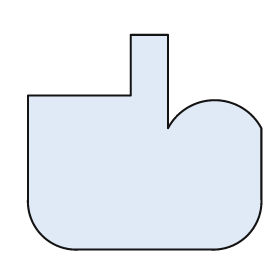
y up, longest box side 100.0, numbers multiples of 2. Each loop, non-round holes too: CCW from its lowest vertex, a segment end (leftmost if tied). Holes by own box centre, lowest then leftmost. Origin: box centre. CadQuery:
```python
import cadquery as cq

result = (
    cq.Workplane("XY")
    .moveTo(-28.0, -46.0)
    .lineTo(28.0, -46.0)
    .threePointArc((44.0, -40.0), (50.0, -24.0))
    .lineTo(50.0, 6.0)
    .threePointArc((30.0, 18.0), (10.0, 6.0))
    .lineTo(10.0, 46.0)
    .lineTo(-6.0, 46.0)
    .lineTo(-6.0, 20.0)
    .lineTo(-50.0, 20.0)
    .lineTo(-50.0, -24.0)
    .threePointArc((-44.0, -40.0), (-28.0, -46.0))
    .close()
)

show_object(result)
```